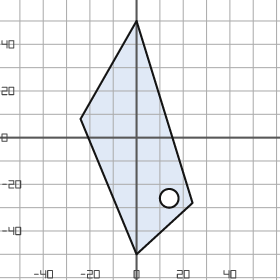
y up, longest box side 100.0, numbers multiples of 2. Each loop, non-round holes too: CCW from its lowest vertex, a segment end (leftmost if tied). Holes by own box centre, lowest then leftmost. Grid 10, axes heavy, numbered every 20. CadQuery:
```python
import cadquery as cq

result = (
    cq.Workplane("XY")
    .moveTo(0.0, -50.0)
    .lineTo(24.0, -28.0)
    .lineTo(0.0, 50.0)
    .lineTo(-24.0, 8.0)
    .close()
    .moveTo(14.0, -26.0)
    .circle(4.0)
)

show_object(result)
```